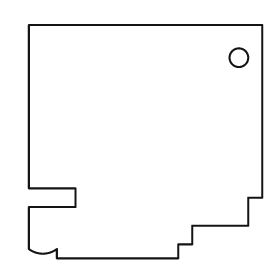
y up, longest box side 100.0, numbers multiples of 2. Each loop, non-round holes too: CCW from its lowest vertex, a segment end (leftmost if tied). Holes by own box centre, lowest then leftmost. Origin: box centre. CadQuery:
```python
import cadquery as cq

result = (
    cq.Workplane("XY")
    .moveTo(-38.0, -50.0)
    .lineTo(14.0, -50.0)
    .lineTo(14.0, -44.0)
    .lineTo(20.0, -44.0)
    .lineTo(20.0, -36.0)
    .lineTo(44.0, -36.0)
    .lineTo(44.0, -24.0)
    .lineTo(50.0, -24.0)
    .lineTo(50.0, 50.0)
    .lineTo(-50.0, 50.0)
    .lineTo(-50.0, -20.0)
    .lineTo(-30.0, -20.0)
    .lineTo(-30.0, -28.0)
    .lineTo(-50.0, -28.0)
    .lineTo(-50.0, -46.0)
    .threePointArc((-44.0, -48.0), (-38.0, -46.0))
    .close()
    .moveTo(40.0, 36.0)
    .circle(4.0)
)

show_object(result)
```